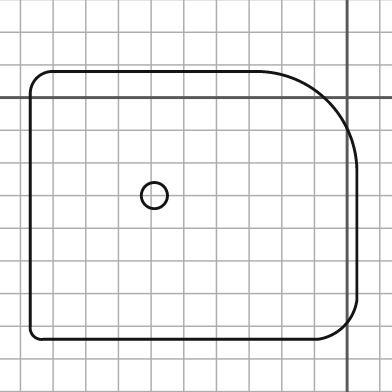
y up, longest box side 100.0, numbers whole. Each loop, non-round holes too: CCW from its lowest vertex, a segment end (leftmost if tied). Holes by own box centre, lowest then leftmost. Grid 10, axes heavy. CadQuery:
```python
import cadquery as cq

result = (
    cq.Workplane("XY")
    .moveTo(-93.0, -74.0)
    .lineTo(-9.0, -74.0)
    .threePointArc((-1.0, -70.0), (3.0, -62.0))
    .lineTo(3.0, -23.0)
    .threePointArc((-6.0, -1.0), (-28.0, 8.0))
    .lineTo(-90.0, 8.0)
    .threePointArc((-95.0, 6.0), (-97.0, 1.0))
    .lineTo(-97.0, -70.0)
    .threePointArc((-96.0, -73.0), (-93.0, -74.0))
    .close()
    .moveTo(-59.0, -30.0)
    .circle(4.0)
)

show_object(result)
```